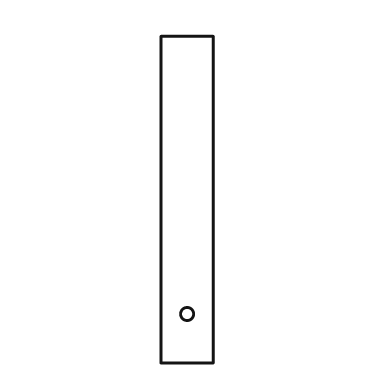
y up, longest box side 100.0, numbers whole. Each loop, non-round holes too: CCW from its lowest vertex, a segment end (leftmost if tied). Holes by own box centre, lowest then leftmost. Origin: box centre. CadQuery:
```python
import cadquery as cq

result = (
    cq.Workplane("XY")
    .moveTo(-8.0, -50.0)
    .lineTo(8.0, -50.0)
    .lineTo(8.0, 50.0)
    .lineTo(-8.0, 50.0)
    .close()
    .moveTo(0.0, -35.0)
    .circle(2.0)
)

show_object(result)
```